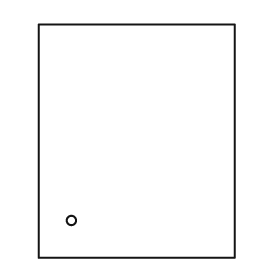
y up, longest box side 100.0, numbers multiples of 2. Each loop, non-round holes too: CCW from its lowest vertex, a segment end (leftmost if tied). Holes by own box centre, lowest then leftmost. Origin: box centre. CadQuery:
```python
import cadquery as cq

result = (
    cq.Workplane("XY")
    .moveTo(-42.0, -50.0)
    .lineTo(42.0, -50.0)
    .lineTo(42.0, 50.0)
    .lineTo(-42.0, 50.0)
    .close()
    .moveTo(-28.0, -34.0)
    .circle(2.0)
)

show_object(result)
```